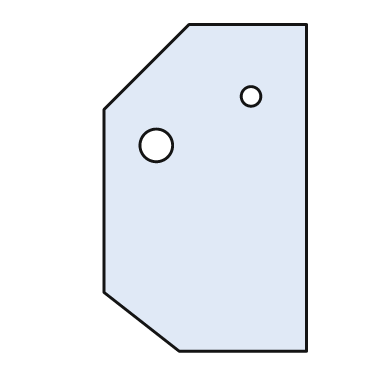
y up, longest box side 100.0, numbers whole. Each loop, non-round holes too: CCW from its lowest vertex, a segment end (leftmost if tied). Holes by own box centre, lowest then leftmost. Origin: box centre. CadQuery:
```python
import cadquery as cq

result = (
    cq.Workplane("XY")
    .moveTo(-8.0, -50.0)
    .lineTo(31.0, -50.0)
    .lineTo(31.0, 50.0)
    .lineTo(-5.0, 50.0)
    .lineTo(-31.0, 24.0)
    .lineTo(-31.0, -32.0)
    .close()
    .moveTo(-15.0, 13.0)
    .circle(5.0)
    .moveTo(14.0, 28.0)
    .circle(3.0)
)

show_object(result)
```